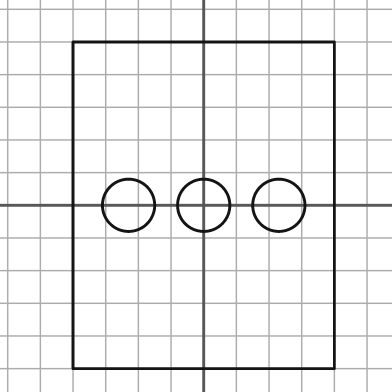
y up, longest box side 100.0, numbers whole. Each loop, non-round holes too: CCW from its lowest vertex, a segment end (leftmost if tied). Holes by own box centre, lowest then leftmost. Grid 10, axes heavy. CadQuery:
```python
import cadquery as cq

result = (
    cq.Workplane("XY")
    .moveTo(-40.0, -50.0)
    .lineTo(40.0, -50.0)
    .lineTo(40.0, 50.0)
    .lineTo(-40.0, 50.0)
    .close()
    .moveTo(-23.0, 0.0)
    .circle(8.0)
    .moveTo(0.0, 0.0)
    .circle(8.0)
    .moveTo(23.0, 0.0)
    .circle(8.0)
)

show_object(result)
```